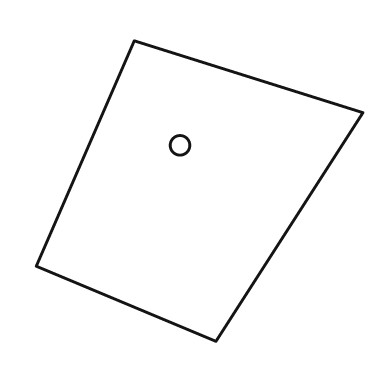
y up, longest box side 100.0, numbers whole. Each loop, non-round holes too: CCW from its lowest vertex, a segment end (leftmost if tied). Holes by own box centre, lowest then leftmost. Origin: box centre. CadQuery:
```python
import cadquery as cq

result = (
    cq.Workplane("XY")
    .moveTo(5.0, -46.0)
    .lineTo(50.0, 24.0)
    .lineTo(-20.0, 46.0)
    .lineTo(-50.0, -23.0)
    .close()
    .moveTo(-6.0, 14.0)
    .circle(3.0)
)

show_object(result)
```